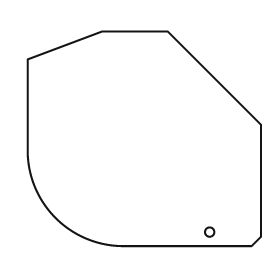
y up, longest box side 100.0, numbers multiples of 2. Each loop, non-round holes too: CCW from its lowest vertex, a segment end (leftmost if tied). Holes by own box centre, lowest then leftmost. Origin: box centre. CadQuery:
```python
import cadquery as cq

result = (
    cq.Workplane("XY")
    .moveTo(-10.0, -46.0)
    .lineTo(46.0, -46.0)
    .lineTo(50.0, -42.0)
    .lineTo(50.0, 6.0)
    .lineTo(10.0, 46.0)
    .lineTo(-18.0, 46.0)
    .lineTo(-50.0, 34.0)
    .lineTo(-50.0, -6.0)
    .threePointArc((-38.0, -34.0), (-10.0, -46.0))
    .close()
    .moveTo(28.0, -40.0)
    .circle(2.0)
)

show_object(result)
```